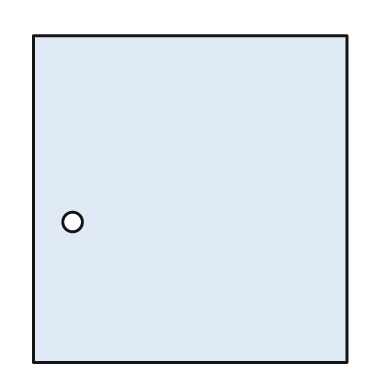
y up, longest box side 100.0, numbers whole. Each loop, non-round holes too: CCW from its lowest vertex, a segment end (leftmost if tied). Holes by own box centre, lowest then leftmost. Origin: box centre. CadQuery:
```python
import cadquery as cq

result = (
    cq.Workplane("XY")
    .moveTo(-48.0, -50.0)
    .lineTo(48.0, -50.0)
    .lineTo(48.0, 50.0)
    .lineTo(-48.0, 50.0)
    .close()
    .moveTo(-36.0, -7.0)
    .circle(3.0)
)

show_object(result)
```